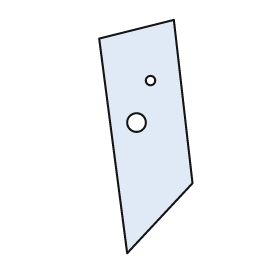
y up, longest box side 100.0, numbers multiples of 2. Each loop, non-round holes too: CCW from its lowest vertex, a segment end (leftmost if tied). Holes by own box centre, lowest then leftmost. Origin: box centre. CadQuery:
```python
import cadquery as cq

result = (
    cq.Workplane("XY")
    .moveTo(-8.0, -50.0)
    .lineTo(20.0, -20.0)
    .lineTo(12.0, 50.0)
    .lineTo(-20.0, 42.0)
    .close()
    .moveTo(-4.0, 6.0)
    .circle(4.0)
    .moveTo(2.0, 24.0)
    .circle(2.0)
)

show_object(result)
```